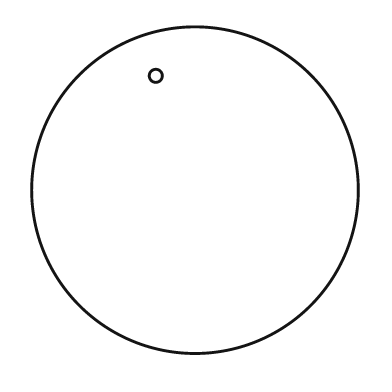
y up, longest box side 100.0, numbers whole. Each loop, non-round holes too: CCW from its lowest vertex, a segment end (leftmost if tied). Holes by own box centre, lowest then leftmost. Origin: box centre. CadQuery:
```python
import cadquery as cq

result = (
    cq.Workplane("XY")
    .moveTo(0.0, 0.0)
    .circle(50.0)
    .moveTo(-12.0, 35.0)
    .circle(2.0)
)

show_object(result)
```